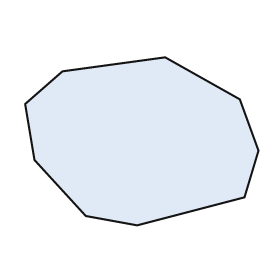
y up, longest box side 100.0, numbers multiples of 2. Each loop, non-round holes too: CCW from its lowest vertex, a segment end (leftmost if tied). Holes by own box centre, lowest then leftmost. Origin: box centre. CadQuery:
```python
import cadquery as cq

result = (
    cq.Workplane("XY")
    .moveTo(-2.0, -36.0)
    .lineTo(44.0, -24.0)
    .lineTo(50.0, -4.0)
    .lineTo(42.0, 18.0)
    .lineTo(10.0, 36.0)
    .lineTo(-34.0, 30.0)
    .lineTo(-50.0, 16.0)
    .lineTo(-46.0, -8.0)
    .lineTo(-24.0, -32.0)
    .close()
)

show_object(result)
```